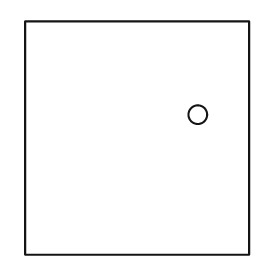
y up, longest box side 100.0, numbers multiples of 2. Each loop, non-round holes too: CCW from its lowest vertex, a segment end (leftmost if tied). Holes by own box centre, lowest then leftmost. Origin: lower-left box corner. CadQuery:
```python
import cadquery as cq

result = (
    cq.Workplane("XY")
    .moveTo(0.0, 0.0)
    .lineTo(96.0, 0.0)
    .lineTo(96.0, 100.0)
    .lineTo(0.0, 100.0)
    .close()
    .moveTo(74.0, 60.0)
    .circle(4.0)
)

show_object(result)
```